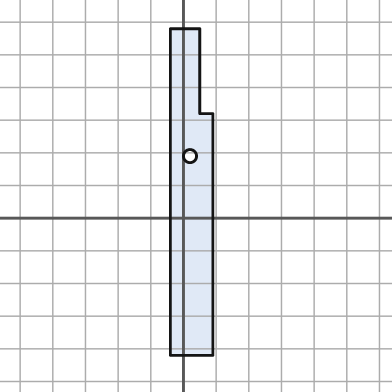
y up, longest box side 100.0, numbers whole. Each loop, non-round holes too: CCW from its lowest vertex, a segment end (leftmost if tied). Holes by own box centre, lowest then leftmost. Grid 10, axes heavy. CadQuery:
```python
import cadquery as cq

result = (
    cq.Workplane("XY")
    .moveTo(-4.0, -42.0)
    .lineTo(9.0, -42.0)
    .lineTo(9.0, 32.0)
    .lineTo(5.0, 32.0)
    .lineTo(5.0, 58.0)
    .lineTo(-4.0, 58.0)
    .close()
    .moveTo(2.0, 19.0)
    .circle(2.0)
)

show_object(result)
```